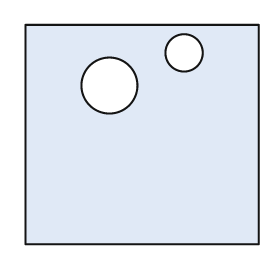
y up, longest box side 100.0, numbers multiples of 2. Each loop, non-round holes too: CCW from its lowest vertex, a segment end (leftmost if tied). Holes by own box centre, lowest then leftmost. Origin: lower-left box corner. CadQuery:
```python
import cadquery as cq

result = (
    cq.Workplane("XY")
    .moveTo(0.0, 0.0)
    .lineTo(100.0, 0.0)
    .lineTo(100.0, 94.0)
    .lineTo(0.0, 94.0)
    .close()
    .moveTo(36.0, 68.0)
    .circle(12.0)
    .moveTo(68.0, 82.0)
    .circle(8.0)
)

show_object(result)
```